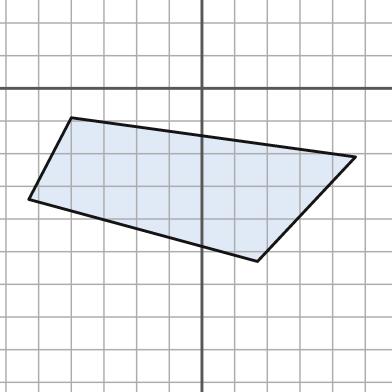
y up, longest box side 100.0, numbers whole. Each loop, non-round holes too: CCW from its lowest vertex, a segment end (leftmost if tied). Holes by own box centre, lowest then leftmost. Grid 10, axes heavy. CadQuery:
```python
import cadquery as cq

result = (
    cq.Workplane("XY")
    .moveTo(17.0, -53.0)
    .lineTo(47.0, -21.0)
    .lineTo(-40.0, -9.0)
    .lineTo(-53.0, -34.0)
    .close()
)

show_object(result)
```